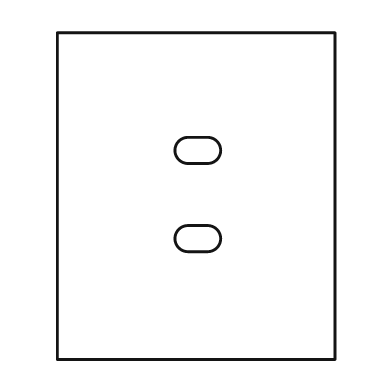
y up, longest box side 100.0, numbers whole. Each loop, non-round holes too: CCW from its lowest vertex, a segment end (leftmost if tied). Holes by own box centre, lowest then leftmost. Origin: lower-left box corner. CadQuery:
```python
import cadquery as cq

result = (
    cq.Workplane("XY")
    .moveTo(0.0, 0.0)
    .lineTo(85.0, 0.0)
    .lineTo(85.0, 100.0)
    .lineTo(0.0, 100.0)
    .close()
    .moveTo(40.0, 33.0)
    .lineTo(46.0, 33.0)
    .threePointArc((50.0, 37.0), (46.0, 41.0))
    .lineTo(40.0, 41.0)
    .threePointArc((36.0, 37.0), (40.0, 33.0))
    .close()
    .moveTo(40.0, 60.0)
    .lineTo(46.0, 60.0)
    .threePointArc((50.0, 64.0), (46.0, 68.0))
    .lineTo(40.0, 68.0)
    .threePointArc((36.0, 64.0), (40.0, 60.0))
    .close()
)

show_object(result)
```